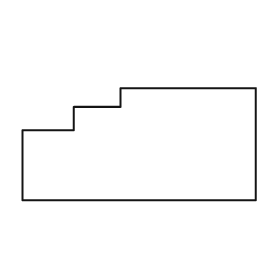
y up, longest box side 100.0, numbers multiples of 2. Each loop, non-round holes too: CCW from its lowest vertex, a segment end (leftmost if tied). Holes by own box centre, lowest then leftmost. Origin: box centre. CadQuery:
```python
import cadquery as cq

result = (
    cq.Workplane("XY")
    .moveTo(-50.0, -24.0)
    .lineTo(50.0, -24.0)
    .lineTo(50.0, 24.0)
    .lineTo(-8.0, 24.0)
    .lineTo(-8.0, 16.0)
    .lineTo(-28.0, 16.0)
    .lineTo(-28.0, 6.0)
    .lineTo(-50.0, 6.0)
    .close()
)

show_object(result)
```